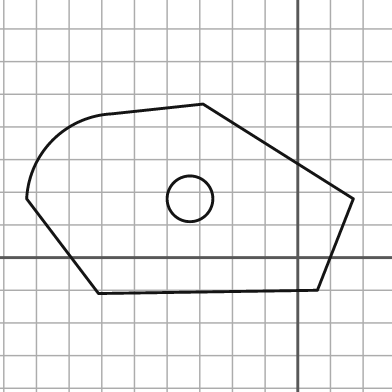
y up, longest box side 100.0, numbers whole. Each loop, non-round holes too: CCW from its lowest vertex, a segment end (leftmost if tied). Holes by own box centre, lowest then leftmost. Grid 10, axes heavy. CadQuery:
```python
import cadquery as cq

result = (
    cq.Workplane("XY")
    .moveTo(-61.0, -11.0)
    .lineTo(6.0, -10.0)
    .lineTo(17.0, 18.0)
    .lineTo(-29.0, 47.0)
    .lineTo(-57.0, 44.0)
    .threePointArc((-75.0, 36.0), (-83.0, 18.0))
    .close()
    .moveTo(-33.0, 18.0)
    .circle(7.0)
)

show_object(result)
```